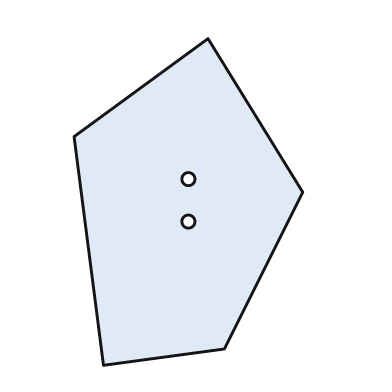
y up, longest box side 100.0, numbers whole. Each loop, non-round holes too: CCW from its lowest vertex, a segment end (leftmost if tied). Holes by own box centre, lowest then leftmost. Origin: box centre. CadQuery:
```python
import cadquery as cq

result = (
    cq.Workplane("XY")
    .moveTo(-26.0, -50.0)
    .lineTo(11.0, -45.0)
    .lineTo(35.0, 3.0)
    .lineTo(6.0, 50.0)
    .lineTo(-35.0, 20.0)
    .close()
    .moveTo(0.0, -6.0)
    .circle(2.0)
    .moveTo(0.0, 7.0)
    .circle(2.0)
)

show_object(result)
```